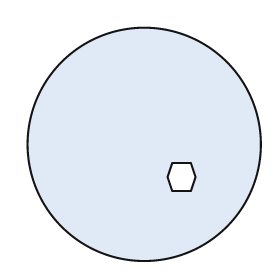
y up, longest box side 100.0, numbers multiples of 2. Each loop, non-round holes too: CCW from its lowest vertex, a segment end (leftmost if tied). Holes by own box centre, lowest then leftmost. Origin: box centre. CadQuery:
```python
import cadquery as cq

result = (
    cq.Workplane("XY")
    .moveTo(0.0, 0.0)
    .circle(50.0)
    .moveTo(12.0, -20.0)
    .lineTo(20.0, -20.0)
    .lineTo(22.0, -14.0)
    .lineTo(20.0, -8.0)
    .lineTo(12.0, -8.0)
    .lineTo(10.0, -14.0)
    .close()
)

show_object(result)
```